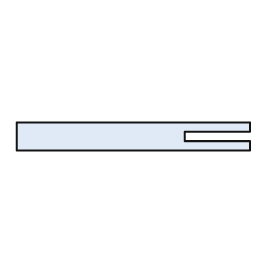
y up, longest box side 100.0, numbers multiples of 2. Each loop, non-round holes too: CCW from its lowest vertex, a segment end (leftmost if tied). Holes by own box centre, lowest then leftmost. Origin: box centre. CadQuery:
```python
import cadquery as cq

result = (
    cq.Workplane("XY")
    .moveTo(-50.0, -6.0)
    .lineTo(50.0, -6.0)
    .lineTo(50.0, -2.0)
    .lineTo(22.0, -2.0)
    .lineTo(22.0, 2.0)
    .lineTo(50.0, 2.0)
    .lineTo(50.0, 6.0)
    .lineTo(-50.0, 6.0)
    .close()
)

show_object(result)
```